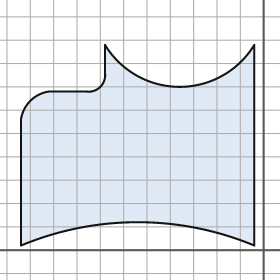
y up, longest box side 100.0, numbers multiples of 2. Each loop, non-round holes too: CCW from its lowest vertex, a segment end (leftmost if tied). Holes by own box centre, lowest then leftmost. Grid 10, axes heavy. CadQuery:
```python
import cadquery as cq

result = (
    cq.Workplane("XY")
    .moveTo(-104.0, 2.0)
    .threePointArc((-54.0, 12.0), (-4.0, 2.0))
    .lineTo(-4.0, 88.0)
    .threePointArc((-36.0, 70.0), (-68.0, 88.0))
    .lineTo(-68.0, 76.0)
    .threePointArc((-70.0, 70.0), (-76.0, 68.0))
    .lineTo(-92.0, 68.0)
    .threePointArc((-100.0, 64.0), (-104.0, 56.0))
    .close()
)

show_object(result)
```